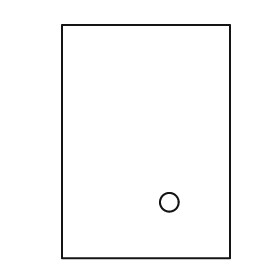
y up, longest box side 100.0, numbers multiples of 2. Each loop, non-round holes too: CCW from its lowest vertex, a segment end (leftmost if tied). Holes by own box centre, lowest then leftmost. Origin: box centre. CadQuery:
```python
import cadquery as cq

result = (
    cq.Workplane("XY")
    .moveTo(-36.0, -50.0)
    .lineTo(36.0, -50.0)
    .lineTo(36.0, 50.0)
    .lineTo(-36.0, 50.0)
    .close()
    .moveTo(10.0, -26.0)
    .circle(4.0)
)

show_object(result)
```